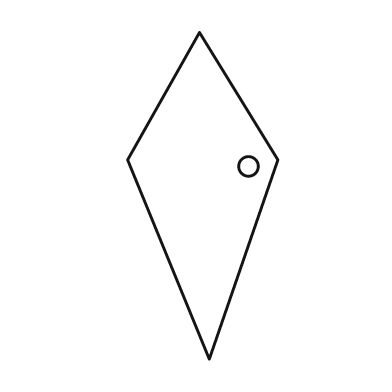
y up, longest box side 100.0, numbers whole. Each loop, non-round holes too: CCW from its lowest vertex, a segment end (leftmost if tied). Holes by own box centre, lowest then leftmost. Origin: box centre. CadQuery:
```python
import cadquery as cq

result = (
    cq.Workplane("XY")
    .moveTo(2.0, -50.0)
    .lineTo(23.0, 11.0)
    .lineTo(-1.0, 50.0)
    .lineTo(-23.0, 11.0)
    .close()
    .moveTo(14.0, 9.0)
    .circle(3.0)
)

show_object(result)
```